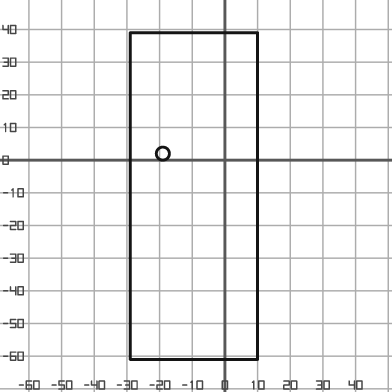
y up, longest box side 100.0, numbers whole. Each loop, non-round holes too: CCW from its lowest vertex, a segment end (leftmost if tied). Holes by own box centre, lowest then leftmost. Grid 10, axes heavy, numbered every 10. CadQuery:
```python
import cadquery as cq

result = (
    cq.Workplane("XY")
    .moveTo(-29.0, -61.0)
    .lineTo(10.0, -61.0)
    .lineTo(10.0, 39.0)
    .lineTo(-29.0, 39.0)
    .close()
    .moveTo(-19.0, 2.0)
    .circle(2.0)
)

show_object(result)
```